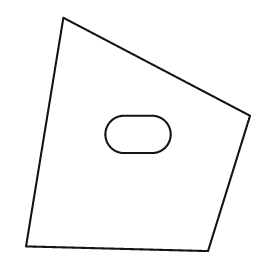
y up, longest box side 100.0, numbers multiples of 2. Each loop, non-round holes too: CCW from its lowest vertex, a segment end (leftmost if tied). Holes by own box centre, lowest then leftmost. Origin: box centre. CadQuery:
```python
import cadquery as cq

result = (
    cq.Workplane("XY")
    .moveTo(30.0, -50.0)
    .lineTo(48.0, 8.0)
    .lineTo(-32.0, 50.0)
    .lineTo(-48.0, -48.0)
    .close()
    .moveTo(-6.0, -8.0)
    .lineTo(6.0, -8.0)
    .threePointArc((14.0, 0.0), (6.0, 8.0))
    .lineTo(-6.0, 8.0)
    .threePointArc((-14.0, 0.0), (-6.0, -8.0))
    .close()
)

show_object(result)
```